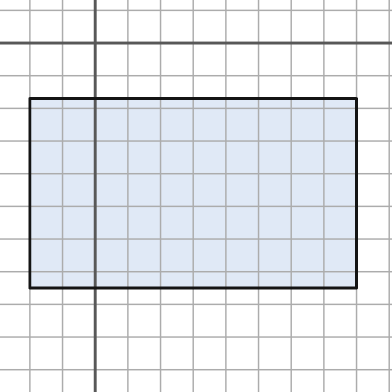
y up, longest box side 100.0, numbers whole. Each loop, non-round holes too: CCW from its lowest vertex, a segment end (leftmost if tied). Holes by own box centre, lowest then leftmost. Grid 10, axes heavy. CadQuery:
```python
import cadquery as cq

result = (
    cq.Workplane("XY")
    .moveTo(-20.0, -75.0)
    .lineTo(80.0, -75.0)
    .lineTo(80.0, -17.0)
    .lineTo(-20.0, -17.0)
    .close()
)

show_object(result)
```